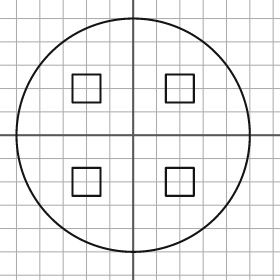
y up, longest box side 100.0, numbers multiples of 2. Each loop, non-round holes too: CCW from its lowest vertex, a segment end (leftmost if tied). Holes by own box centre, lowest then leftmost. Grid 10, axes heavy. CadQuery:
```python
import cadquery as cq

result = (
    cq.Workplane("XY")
    .moveTo(0.0, 0.0)
    .circle(50.0)
    .moveTo(-26.0, -26.0)
    .lineTo(-14.0, -26.0)
    .lineTo(-14.0, -14.0)
    .lineTo(-26.0, -14.0)
    .close()
    .moveTo(14.0, -26.0)
    .lineTo(26.0, -26.0)
    .lineTo(26.0, -14.0)
    .lineTo(14.0, -14.0)
    .close()
    .moveTo(-26.0, 14.0)
    .lineTo(-14.0, 14.0)
    .lineTo(-14.0, 26.0)
    .lineTo(-26.0, 26.0)
    .close()
    .moveTo(14.0, 14.0)
    .lineTo(26.0, 14.0)
    .lineTo(26.0, 26.0)
    .lineTo(14.0, 26.0)
    .close()
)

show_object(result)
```